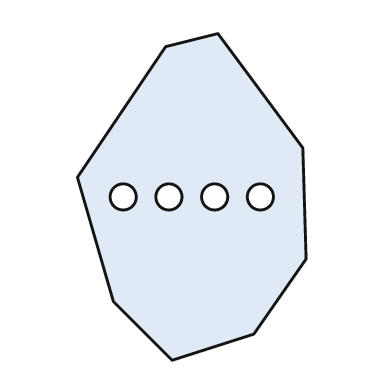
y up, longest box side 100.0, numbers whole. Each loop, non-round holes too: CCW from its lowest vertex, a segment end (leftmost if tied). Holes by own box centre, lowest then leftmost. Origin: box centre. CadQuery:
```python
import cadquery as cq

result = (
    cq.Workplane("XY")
    .moveTo(-6.0, -50.0)
    .lineTo(19.0, -42.0)
    .lineTo(35.0, -19.0)
    .lineTo(34.0, 15.0)
    .lineTo(8.0, 50.0)
    .lineTo(-8.0, 46.0)
    .lineTo(-35.0, 6.0)
    .lineTo(-24.0, -32.0)
    .close()
    .moveTo(-21.0, 0.0)
    .circle(4.0)
    .moveTo(-7.0, 0.0)
    .circle(4.0)
    .moveTo(7.0, 0.0)
    .circle(4.0)
    .moveTo(21.0, 0.0)
    .circle(4.0)
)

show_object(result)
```